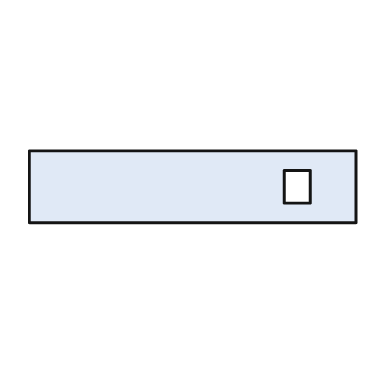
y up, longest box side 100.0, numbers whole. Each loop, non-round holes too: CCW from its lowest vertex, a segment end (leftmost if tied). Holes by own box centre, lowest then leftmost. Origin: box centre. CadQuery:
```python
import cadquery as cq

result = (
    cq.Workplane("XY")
    .moveTo(-50.0, -11.0)
    .lineTo(50.0, -11.0)
    .lineTo(50.0, 11.0)
    .lineTo(-50.0, 11.0)
    .close()
    .moveTo(28.0, -5.0)
    .lineTo(36.0, -5.0)
    .lineTo(36.0, 5.0)
    .lineTo(28.0, 5.0)
    .close()
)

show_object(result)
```